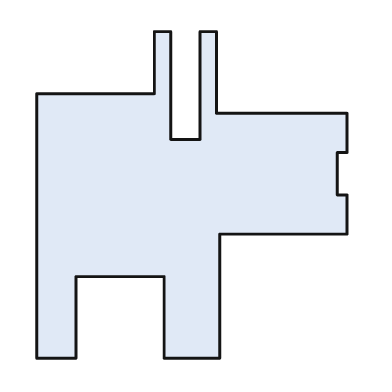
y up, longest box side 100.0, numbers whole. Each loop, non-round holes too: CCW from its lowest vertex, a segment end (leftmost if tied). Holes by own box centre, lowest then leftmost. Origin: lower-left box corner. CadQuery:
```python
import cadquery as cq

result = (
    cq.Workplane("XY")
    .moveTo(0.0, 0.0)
    .lineTo(12.0, 0.0)
    .lineTo(12.0, 25.0)
    .lineTo(39.0, 25.0)
    .lineTo(39.0, 0.0)
    .lineTo(56.0, 0.0)
    .lineTo(56.0, 38.0)
    .lineTo(95.0, 38.0)
    .lineTo(95.0, 50.0)
    .lineTo(92.0, 50.0)
    .lineTo(92.0, 63.0)
    .lineTo(95.0, 63.0)
    .lineTo(95.0, 75.0)
    .lineTo(55.0, 75.0)
    .lineTo(55.0, 100.0)
    .lineTo(50.0, 100.0)
    .lineTo(50.0, 67.0)
    .lineTo(41.0, 67.0)
    .lineTo(41.0, 100.0)
    .lineTo(36.0, 100.0)
    .lineTo(36.0, 81.0)
    .lineTo(0.0, 81.0)
    .close()
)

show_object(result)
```